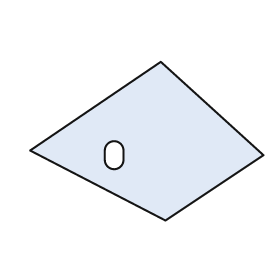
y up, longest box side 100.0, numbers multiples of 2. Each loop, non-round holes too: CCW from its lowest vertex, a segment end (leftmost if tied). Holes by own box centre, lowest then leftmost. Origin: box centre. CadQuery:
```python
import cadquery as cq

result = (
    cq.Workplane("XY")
    .moveTo(8.0, -34.0)
    .lineTo(50.0, -6.0)
    .lineTo(6.0, 34.0)
    .lineTo(-50.0, -4.0)
    .close()
    .moveTo(-18.0, -8.0)
    .threePointArc((-14.0, -12.0), (-10.0, -8.0))
    .lineTo(-10.0, -4.0)
    .threePointArc((-14.0, 0.0), (-18.0, -4.0))
    .close()
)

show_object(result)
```